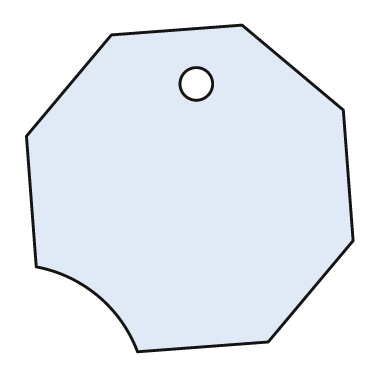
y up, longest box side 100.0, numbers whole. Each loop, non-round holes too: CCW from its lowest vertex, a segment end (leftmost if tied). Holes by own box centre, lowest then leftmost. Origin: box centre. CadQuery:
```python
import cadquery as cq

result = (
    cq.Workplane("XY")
    .moveTo(-16.0, -50.0)
    .lineTo(24.0, -47.0)
    .lineTo(50.0, -16.0)
    .lineTo(47.0, 24.0)
    .lineTo(16.0, 50.0)
    .lineTo(-24.0, 47.0)
    .lineTo(-50.0, 16.0)
    .lineTo(-47.0, -24.0)
    .threePointArc((-28.0, -33.0), (-16.0, -50.0))
    .close()
    .moveTo(2.0, 32.0)
    .circle(5.0)
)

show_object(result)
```